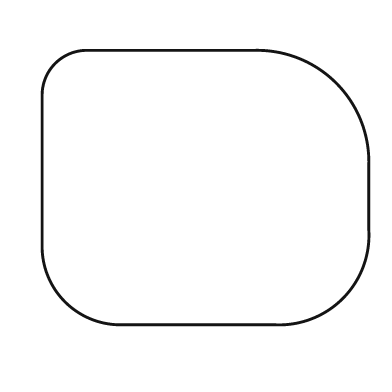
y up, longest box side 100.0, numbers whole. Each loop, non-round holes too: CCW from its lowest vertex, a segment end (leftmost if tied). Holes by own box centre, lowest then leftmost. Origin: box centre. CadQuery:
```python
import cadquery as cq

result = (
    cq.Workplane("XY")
    .moveTo(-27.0, -42.0)
    .lineTo(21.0, -42.0)
    .threePointArc((42.0, -34.0), (50.0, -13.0))
    .lineTo(50.0, 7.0)
    .threePointArc((40.0, 32.0), (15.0, 42.0))
    .lineTo(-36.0, 42.0)
    .threePointArc((-46.0, 38.0), (-50.0, 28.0))
    .lineTo(-50.0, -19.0)
    .threePointArc((-43.0, -35.0), (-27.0, -42.0))
    .close()
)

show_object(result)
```